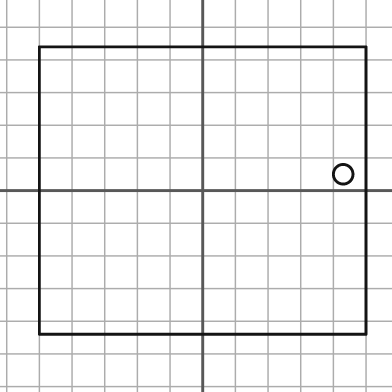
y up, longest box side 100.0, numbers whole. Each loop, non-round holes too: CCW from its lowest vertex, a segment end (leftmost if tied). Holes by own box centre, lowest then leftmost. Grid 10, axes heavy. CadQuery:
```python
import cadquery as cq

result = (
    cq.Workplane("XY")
    .moveTo(-50.0, -44.0)
    .lineTo(50.0, -44.0)
    .lineTo(50.0, 44.0)
    .lineTo(-50.0, 44.0)
    .close()
    .moveTo(43.0, 5.0)
    .circle(3.0)
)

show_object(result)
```